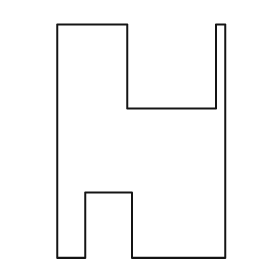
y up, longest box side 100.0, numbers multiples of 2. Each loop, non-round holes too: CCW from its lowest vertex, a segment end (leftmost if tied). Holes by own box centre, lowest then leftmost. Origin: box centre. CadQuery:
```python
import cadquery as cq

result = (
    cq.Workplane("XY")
    .moveTo(-36.0, -50.0)
    .lineTo(-24.0, -50.0)
    .lineTo(-24.0, -22.0)
    .lineTo(-4.0, -22.0)
    .lineTo(-4.0, -50.0)
    .lineTo(36.0, -50.0)
    .lineTo(36.0, 50.0)
    .lineTo(32.0, 50.0)
    .lineTo(32.0, 14.0)
    .lineTo(-6.0, 14.0)
    .lineTo(-6.0, 50.0)
    .lineTo(-36.0, 50.0)
    .close()
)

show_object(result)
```